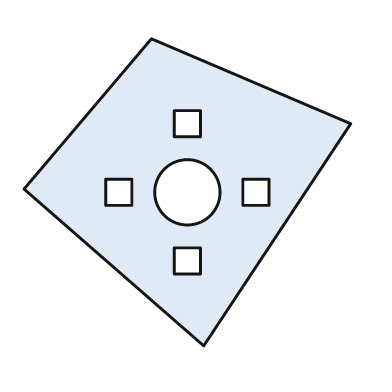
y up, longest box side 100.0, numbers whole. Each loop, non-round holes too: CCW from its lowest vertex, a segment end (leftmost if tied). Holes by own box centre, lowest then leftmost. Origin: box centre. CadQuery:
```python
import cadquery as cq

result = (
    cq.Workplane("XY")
    .moveTo(5.0, -47.0)
    .lineTo(50.0, 21.0)
    .lineTo(-11.0, 47.0)
    .lineTo(-50.0, 1.0)
    .close()
    .moveTo(-4.0, -25.0)
    .lineTo(4.0, -25.0)
    .lineTo(4.0, -17.0)
    .lineTo(-4.0, -17.0)
    .close()
    .moveTo(-25.0, -4.0)
    .lineTo(-17.0, -4.0)
    .lineTo(-17.0, 4.0)
    .lineTo(-25.0, 4.0)
    .close()
    .moveTo(0.0, 0.0)
    .circle(10.0)
    .moveTo(17.0, -4.0)
    .lineTo(25.0, -4.0)
    .lineTo(25.0, 4.0)
    .lineTo(17.0, 4.0)
    .close()
    .moveTo(-4.0, 17.0)
    .lineTo(4.0, 17.0)
    .lineTo(4.0, 25.0)
    .lineTo(-4.0, 25.0)
    .close()
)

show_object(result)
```